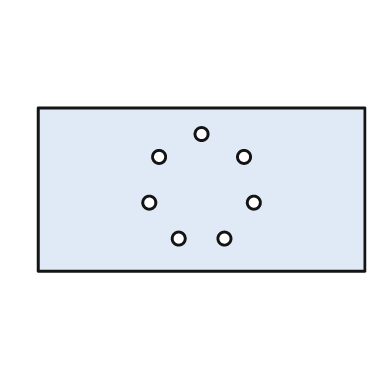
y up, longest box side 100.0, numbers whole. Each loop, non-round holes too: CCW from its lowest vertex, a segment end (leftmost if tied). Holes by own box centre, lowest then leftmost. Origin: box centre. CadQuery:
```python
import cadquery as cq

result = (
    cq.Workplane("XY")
    .moveTo(-50.0, -25.0)
    .lineTo(50.0, -25.0)
    .lineTo(50.0, 25.0)
    .lineTo(-50.0, 25.0)
    .close()
    .moveTo(-7.0, -15.0)
    .circle(2.0)
    .moveTo(7.0, -15.0)
    .circle(2.0)
    .moveTo(-16.0, -4.0)
    .circle(2.0)
    .moveTo(16.0, -4.0)
    .circle(2.0)
    .moveTo(-13.0, 10.0)
    .circle(2.0)
    .moveTo(13.0, 10.0)
    .circle(2.0)
    .moveTo(0.0, 17.0)
    .circle(2.0)
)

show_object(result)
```